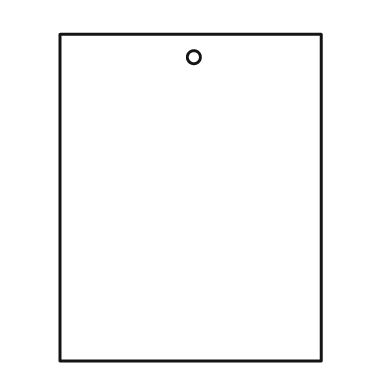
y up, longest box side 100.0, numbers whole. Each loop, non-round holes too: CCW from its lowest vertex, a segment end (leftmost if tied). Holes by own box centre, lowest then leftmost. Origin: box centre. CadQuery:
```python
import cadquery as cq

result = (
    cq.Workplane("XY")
    .moveTo(-40.0, -50.0)
    .lineTo(40.0, -50.0)
    .lineTo(40.0, 50.0)
    .lineTo(-40.0, 50.0)
    .close()
    .moveTo(1.0, 43.0)
    .circle(2.0)
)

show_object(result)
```